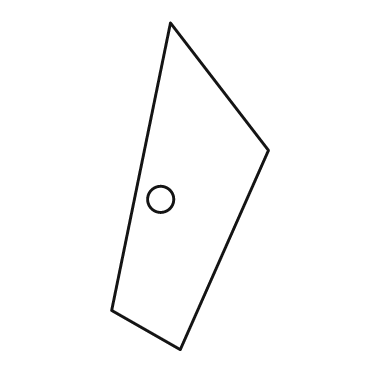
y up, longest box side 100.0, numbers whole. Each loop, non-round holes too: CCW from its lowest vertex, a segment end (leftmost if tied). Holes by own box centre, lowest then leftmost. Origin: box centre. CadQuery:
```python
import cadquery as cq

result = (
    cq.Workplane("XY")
    .moveTo(-3.0, -50.0)
    .lineTo(24.0, 11.0)
    .lineTo(-6.0, 50.0)
    .lineTo(-24.0, -38.0)
    .close()
    .moveTo(-9.0, -4.0)
    .circle(4.0)
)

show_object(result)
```